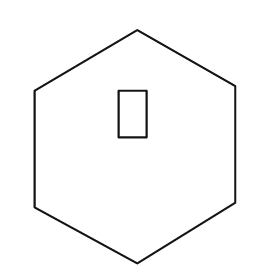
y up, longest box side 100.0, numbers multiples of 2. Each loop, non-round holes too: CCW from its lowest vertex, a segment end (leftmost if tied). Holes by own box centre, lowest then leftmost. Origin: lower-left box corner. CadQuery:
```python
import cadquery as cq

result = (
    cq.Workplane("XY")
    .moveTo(44.0, 0.0)
    .lineTo(86.0, 26.0)
    .lineTo(86.0, 76.0)
    .lineTo(44.0, 100.0)
    .lineTo(0.0, 74.0)
    .lineTo(0.0, 24.0)
    .close()
    .moveTo(36.0, 54.0)
    .lineTo(48.0, 54.0)
    .lineTo(48.0, 74.0)
    .lineTo(36.0, 74.0)
    .close()
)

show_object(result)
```